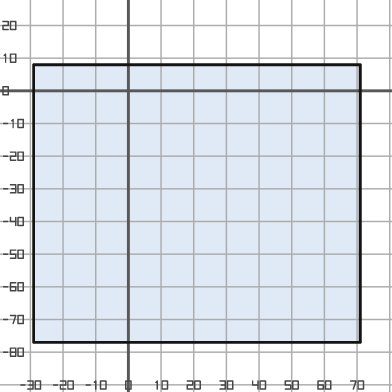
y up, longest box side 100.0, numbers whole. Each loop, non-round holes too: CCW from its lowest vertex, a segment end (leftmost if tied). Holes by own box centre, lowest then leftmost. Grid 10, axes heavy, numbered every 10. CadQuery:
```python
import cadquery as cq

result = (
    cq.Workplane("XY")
    .moveTo(-29.0, -77.0)
    .lineTo(71.0, -77.0)
    .lineTo(71.0, 8.0)
    .lineTo(-29.0, 8.0)
    .close()
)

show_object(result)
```